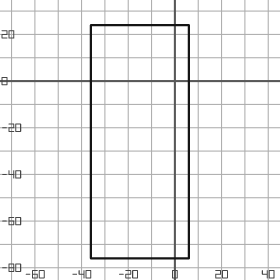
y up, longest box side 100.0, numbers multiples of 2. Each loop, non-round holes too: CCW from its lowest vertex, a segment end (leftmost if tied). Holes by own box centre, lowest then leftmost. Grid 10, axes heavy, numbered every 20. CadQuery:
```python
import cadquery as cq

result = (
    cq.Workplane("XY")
    .moveTo(-36.0, -76.0)
    .lineTo(6.0, -76.0)
    .lineTo(6.0, 24.0)
    .lineTo(-36.0, 24.0)
    .close()
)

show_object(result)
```